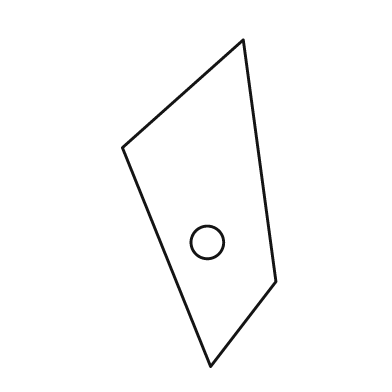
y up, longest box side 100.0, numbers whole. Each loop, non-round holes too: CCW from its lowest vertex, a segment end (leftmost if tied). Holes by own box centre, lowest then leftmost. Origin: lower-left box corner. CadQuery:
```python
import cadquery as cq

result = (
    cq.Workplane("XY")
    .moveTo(27.0, 0.0)
    .lineTo(47.0, 26.0)
    .lineTo(37.0, 100.0)
    .lineTo(0.0, 67.0)
    .close()
    .moveTo(26.0, 38.0)
    .circle(5.0)
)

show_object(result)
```